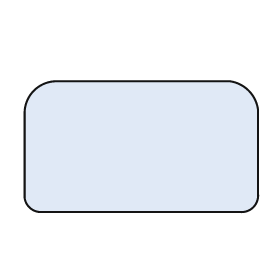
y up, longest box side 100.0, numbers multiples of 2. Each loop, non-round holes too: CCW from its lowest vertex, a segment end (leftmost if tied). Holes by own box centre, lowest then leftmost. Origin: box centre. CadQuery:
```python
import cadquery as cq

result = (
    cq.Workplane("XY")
    .moveTo(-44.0, -28.0)
    .lineTo(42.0, -28.0)
    .threePointArc((48.0, -26.0), (50.0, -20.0))
    .lineTo(50.0, 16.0)
    .threePointArc((46.0, 24.0), (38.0, 28.0))
    .lineTo(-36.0, 28.0)
    .threePointArc((-46.0, 24.0), (-50.0, 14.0))
    .lineTo(-50.0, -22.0)
    .threePointArc((-48.0, -26.0), (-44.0, -28.0))
    .close()
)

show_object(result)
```